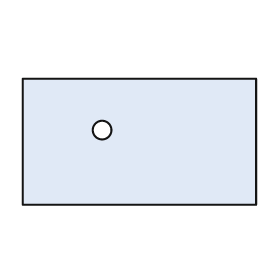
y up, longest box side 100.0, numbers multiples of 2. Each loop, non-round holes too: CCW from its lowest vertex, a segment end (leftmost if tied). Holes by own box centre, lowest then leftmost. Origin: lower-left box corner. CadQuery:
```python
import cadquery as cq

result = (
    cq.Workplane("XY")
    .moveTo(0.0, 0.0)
    .lineTo(100.0, 0.0)
    .lineTo(100.0, 54.0)
    .lineTo(0.0, 54.0)
    .close()
    .moveTo(34.0, 32.0)
    .circle(4.0)
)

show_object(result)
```